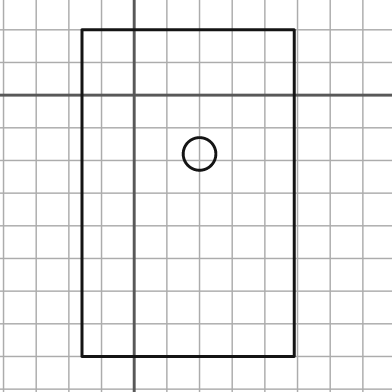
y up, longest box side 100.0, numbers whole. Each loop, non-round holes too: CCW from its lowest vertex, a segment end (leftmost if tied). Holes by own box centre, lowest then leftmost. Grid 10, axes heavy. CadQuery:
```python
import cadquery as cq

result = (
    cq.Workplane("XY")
    .moveTo(-16.0, -80.0)
    .lineTo(49.0, -80.0)
    .lineTo(49.0, 20.0)
    .lineTo(-16.0, 20.0)
    .close()
    .moveTo(20.0, -18.0)
    .circle(5.0)
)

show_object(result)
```